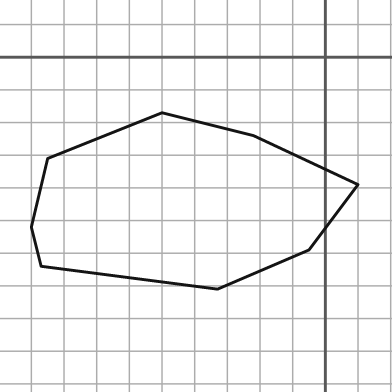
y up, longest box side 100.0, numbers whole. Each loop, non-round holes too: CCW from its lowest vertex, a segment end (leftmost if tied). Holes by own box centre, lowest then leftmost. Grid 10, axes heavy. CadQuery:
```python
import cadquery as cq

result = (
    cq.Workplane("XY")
    .moveTo(-33.0, -71.0)
    .lineTo(-5.0, -59.0)
    .lineTo(10.0, -39.0)
    .lineTo(-22.0, -24.0)
    .lineTo(-50.0, -17.0)
    .lineTo(-85.0, -31.0)
    .lineTo(-90.0, -52.0)
    .lineTo(-87.0, -64.0)
    .close()
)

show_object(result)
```